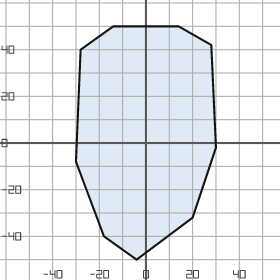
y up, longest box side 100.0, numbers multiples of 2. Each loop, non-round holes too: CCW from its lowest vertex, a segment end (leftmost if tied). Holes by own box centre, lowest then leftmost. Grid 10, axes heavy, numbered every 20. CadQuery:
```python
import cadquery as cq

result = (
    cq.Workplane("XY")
    .moveTo(-4.0, -50.0)
    .lineTo(20.0, -32.0)
    .lineTo(30.0, -2.0)
    .lineTo(28.0, 42.0)
    .lineTo(14.0, 50.0)
    .lineTo(-14.0, 50.0)
    .lineTo(-28.0, 40.0)
    .lineTo(-30.0, -8.0)
    .lineTo(-18.0, -40.0)
    .close()
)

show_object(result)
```